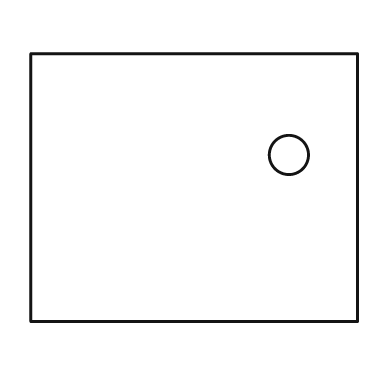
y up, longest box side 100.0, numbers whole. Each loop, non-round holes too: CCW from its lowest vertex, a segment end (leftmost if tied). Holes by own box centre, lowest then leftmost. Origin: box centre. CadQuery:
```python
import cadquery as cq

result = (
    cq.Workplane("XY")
    .moveTo(-50.0, -41.0)
    .lineTo(50.0, -41.0)
    .lineTo(50.0, 41.0)
    .lineTo(-50.0, 41.0)
    .close()
    .moveTo(29.0, 10.0)
    .circle(6.0)
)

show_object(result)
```